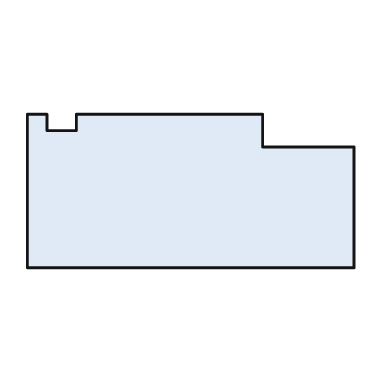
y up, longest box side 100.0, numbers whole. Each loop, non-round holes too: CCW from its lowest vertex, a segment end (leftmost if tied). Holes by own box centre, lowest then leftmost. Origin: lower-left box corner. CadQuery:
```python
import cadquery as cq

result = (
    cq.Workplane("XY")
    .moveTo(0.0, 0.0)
    .lineTo(100.0, 0.0)
    .lineTo(100.0, 37.0)
    .lineTo(72.0, 37.0)
    .lineTo(72.0, 47.0)
    .lineTo(15.0, 47.0)
    .lineTo(15.0, 42.0)
    .lineTo(6.0, 42.0)
    .lineTo(6.0, 47.0)
    .lineTo(0.0, 47.0)
    .close()
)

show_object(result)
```